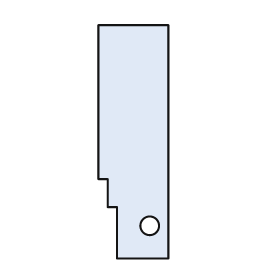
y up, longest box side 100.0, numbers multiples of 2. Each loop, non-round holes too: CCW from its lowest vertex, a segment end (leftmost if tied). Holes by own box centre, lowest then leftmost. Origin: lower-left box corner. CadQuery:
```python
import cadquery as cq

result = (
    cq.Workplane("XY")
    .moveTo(8.0, 0.0)
    .lineTo(30.0, 0.0)
    .lineTo(30.0, 100.0)
    .lineTo(0.0, 100.0)
    .lineTo(0.0, 34.0)
    .lineTo(4.0, 34.0)
    .lineTo(4.0, 22.0)
    .lineTo(8.0, 22.0)
    .close()
    .moveTo(22.0, 14.0)
    .circle(4.0)
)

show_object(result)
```